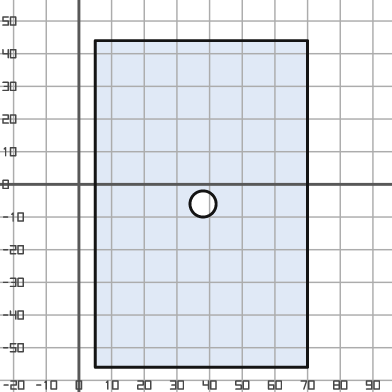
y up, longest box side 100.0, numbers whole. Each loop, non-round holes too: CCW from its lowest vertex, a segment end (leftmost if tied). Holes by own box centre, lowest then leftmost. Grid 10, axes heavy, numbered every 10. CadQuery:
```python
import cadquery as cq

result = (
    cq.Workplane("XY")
    .moveTo(5.0, -56.0)
    .lineTo(70.0, -56.0)
    .lineTo(70.0, 44.0)
    .lineTo(5.0, 44.0)
    .close()
    .moveTo(38.0, -6.0)
    .circle(4.0)
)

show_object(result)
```